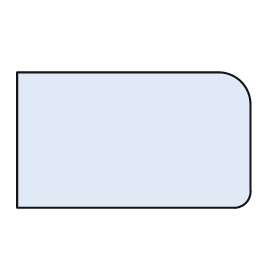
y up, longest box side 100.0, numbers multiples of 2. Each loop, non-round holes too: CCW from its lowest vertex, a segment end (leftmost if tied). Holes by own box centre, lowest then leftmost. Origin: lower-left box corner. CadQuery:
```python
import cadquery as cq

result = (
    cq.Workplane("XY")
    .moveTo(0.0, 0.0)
    .lineTo(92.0, 0.0)
    .threePointArc((98.0, 2.0), (100.0, 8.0))
    .lineTo(100.0, 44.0)
    .threePointArc((96.0, 54.0), (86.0, 58.0))
    .lineTo(0.0, 58.0)
    .close()
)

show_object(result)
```